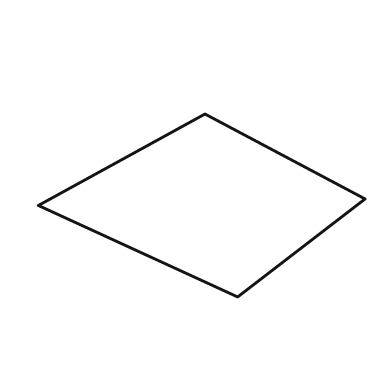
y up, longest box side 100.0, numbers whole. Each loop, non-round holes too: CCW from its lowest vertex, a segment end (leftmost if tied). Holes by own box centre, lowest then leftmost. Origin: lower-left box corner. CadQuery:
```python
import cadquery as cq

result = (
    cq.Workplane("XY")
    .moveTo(61.0, 0.0)
    .lineTo(100.0, 30.0)
    .lineTo(51.0, 56.0)
    .lineTo(0.0, 28.0)
    .close()
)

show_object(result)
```